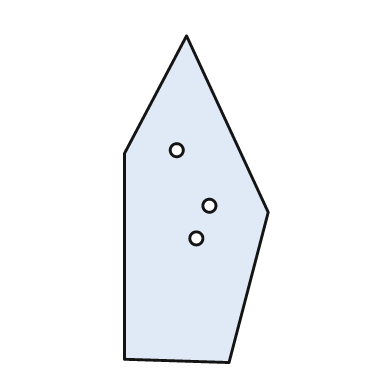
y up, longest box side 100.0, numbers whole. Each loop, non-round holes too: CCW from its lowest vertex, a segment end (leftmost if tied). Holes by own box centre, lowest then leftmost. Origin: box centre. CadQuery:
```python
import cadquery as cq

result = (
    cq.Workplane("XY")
    .moveTo(10.0, -50.0)
    .lineTo(22.0, -4.0)
    .lineTo(-3.0, 50.0)
    .lineTo(-22.0, 14.0)
    .lineTo(-22.0, -49.0)
    .close()
    .moveTo(0.0, -12.0)
    .circle(2.0)
    .moveTo(4.0, -2.0)
    .circle(2.0)
    .moveTo(-6.0, 15.0)
    .circle(2.0)
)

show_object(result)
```